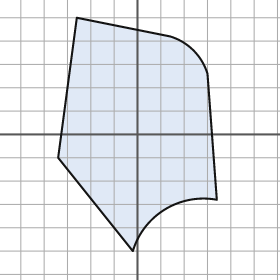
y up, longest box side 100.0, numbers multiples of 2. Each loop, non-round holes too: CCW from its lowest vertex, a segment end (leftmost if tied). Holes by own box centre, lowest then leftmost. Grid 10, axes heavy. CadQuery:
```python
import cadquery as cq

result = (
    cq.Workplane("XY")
    .moveTo(-2.0, -50.0)
    .threePointArc((12.0, -32.0), (34.0, -28.0))
    .lineTo(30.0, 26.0)
    .threePointArc((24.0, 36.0), (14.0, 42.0))
    .lineTo(-26.0, 50.0)
    .lineTo(-34.0, -10.0)
    .close()
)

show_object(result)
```